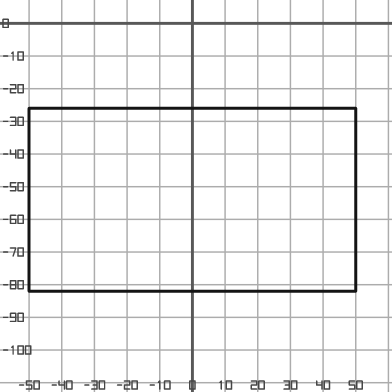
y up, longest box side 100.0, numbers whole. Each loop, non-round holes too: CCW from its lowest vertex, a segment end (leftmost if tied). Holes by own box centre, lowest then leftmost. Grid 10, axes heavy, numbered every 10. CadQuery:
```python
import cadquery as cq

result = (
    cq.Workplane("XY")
    .moveTo(-50.0, -82.0)
    .lineTo(50.0, -82.0)
    .lineTo(50.0, -26.0)
    .lineTo(-50.0, -26.0)
    .close()
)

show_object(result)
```